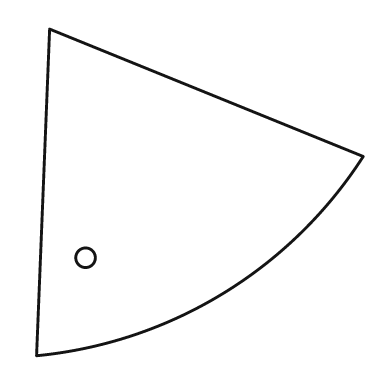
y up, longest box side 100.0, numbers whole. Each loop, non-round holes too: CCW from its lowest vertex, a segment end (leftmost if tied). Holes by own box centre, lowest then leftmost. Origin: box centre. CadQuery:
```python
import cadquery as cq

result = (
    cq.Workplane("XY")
    .moveTo(-50.0, -50.0)
    .threePointArc((7.0, -31.0), (50.0, 11.0))
    .lineTo(-46.0, 50.0)
    .close()
    .moveTo(-35.0, -20.0)
    .circle(3.0)
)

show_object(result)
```